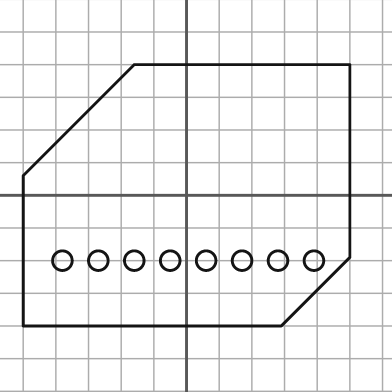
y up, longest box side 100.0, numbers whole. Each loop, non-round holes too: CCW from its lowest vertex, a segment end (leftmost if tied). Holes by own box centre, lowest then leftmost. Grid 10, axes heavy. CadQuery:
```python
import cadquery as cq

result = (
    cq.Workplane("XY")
    .moveTo(-50.0, -40.0)
    .lineTo(29.0, -40.0)
    .lineTo(50.0, -19.0)
    .lineTo(50.0, 40.0)
    .lineTo(-16.0, 40.0)
    .lineTo(-50.0, 6.0)
    .close()
    .moveTo(-38.0, -20.0)
    .circle(3.0)
    .moveTo(-27.0, -20.0)
    .circle(3.0)
    .moveTo(-16.0, -20.0)
    .circle(3.0)
    .moveTo(-5.0, -20.0)
    .circle(3.0)
    .moveTo(6.0, -20.0)
    .circle(3.0)
    .moveTo(17.0, -20.0)
    .circle(3.0)
    .moveTo(28.0, -20.0)
    .circle(3.0)
    .moveTo(39.0, -20.0)
    .circle(3.0)
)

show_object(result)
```